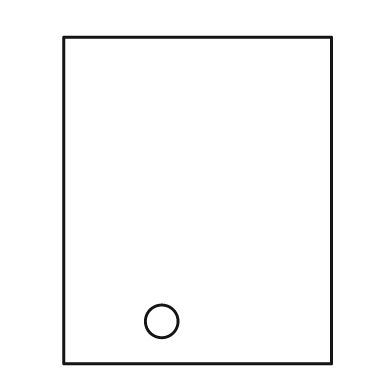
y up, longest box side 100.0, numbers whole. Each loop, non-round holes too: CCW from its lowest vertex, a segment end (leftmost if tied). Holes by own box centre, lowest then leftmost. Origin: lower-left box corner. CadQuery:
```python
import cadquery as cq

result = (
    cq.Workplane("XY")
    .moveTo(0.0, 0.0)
    .lineTo(82.0, 0.0)
    .lineTo(82.0, 100.0)
    .lineTo(0.0, 100.0)
    .close()
    .moveTo(30.0, 13.0)
    .circle(5.0)
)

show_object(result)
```